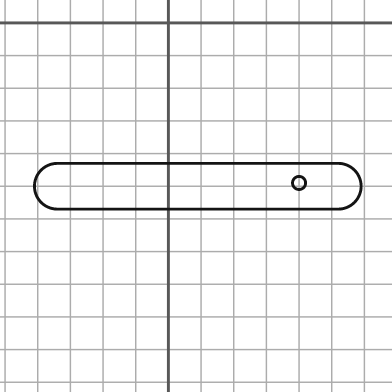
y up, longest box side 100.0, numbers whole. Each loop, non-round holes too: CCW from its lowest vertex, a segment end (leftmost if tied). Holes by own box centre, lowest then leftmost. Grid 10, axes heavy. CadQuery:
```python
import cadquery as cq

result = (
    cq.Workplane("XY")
    .moveTo(-34.0, -57.0)
    .lineTo(52.0, -57.0)
    .threePointArc((59.0, -50.0), (52.0, -43.0))
    .lineTo(-34.0, -43.0)
    .threePointArc((-41.0, -50.0), (-34.0, -57.0))
    .close()
    .moveTo(40.0, -49.0)
    .circle(2.0)
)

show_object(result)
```